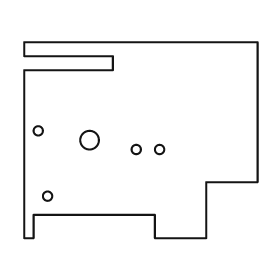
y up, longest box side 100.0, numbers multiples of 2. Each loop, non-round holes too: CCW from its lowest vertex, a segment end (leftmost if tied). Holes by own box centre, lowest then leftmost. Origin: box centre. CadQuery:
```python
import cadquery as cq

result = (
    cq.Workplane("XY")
    .moveTo(-50.0, -42.0)
    .lineTo(-46.0, -42.0)
    .lineTo(-46.0, -32.0)
    .lineTo(6.0, -32.0)
    .lineTo(6.0, -42.0)
    .lineTo(28.0, -42.0)
    .lineTo(28.0, -18.0)
    .lineTo(50.0, -18.0)
    .lineTo(50.0, 42.0)
    .lineTo(-50.0, 42.0)
    .lineTo(-50.0, 36.0)
    .lineTo(-12.0, 36.0)
    .lineTo(-12.0, 30.0)
    .lineTo(-50.0, 30.0)
    .close()
    .moveTo(-40.0, -24.0)
    .circle(2.0)
    .moveTo(-2.0, -4.0)
    .circle(2.0)
    .moveTo(8.0, -4.0)
    .circle(2.0)
    .moveTo(-22.0, 0.0)
    .circle(4.0)
    .moveTo(-44.0, 4.0)
    .circle(2.0)
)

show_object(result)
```